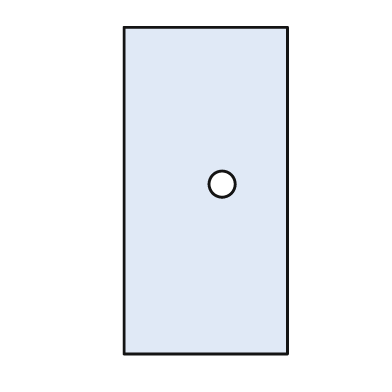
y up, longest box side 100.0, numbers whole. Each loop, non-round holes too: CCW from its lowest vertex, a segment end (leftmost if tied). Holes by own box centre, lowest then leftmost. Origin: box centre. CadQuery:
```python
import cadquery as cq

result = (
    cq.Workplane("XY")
    .moveTo(-25.0, -50.0)
    .lineTo(25.0, -50.0)
    .lineTo(25.0, 50.0)
    .lineTo(-25.0, 50.0)
    .close()
    .moveTo(5.0, 2.0)
    .circle(4.0)
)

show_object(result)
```